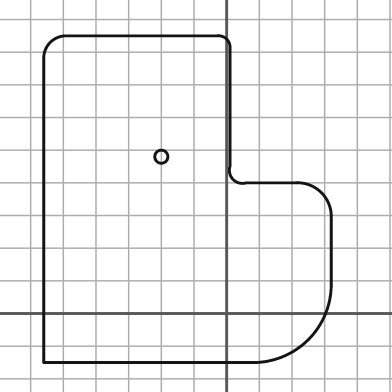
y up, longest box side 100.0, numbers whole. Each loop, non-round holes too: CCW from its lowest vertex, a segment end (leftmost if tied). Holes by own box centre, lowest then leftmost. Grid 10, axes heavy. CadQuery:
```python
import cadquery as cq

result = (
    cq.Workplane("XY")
    .moveTo(-56.0, -15.0)
    .lineTo(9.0, -15.0)
    .threePointArc((25.0, -8.0), (32.0, 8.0))
    .lineTo(32.0, 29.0)
    .threePointArc((29.0, 37.0), (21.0, 40.0))
    .lineTo(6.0, 40.0)
    .threePointArc((2.0, 41.0), (1.0, 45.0))
    .lineTo(1.0, 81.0)
    .threePointArc((0.0, 84.0), (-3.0, 85.0))
    .lineTo(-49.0, 85.0)
    .threePointArc((-54.0, 83.0), (-56.0, 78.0))
    .close()
    .moveTo(-20.0, 48.0)
    .circle(2.0)
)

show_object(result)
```